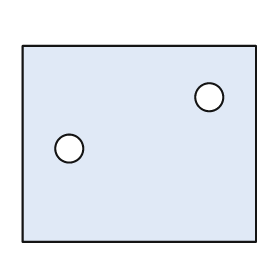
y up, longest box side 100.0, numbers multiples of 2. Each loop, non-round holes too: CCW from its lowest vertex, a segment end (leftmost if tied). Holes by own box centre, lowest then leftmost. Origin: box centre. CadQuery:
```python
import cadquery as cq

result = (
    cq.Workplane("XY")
    .moveTo(-50.0, -42.0)
    .lineTo(50.0, -42.0)
    .lineTo(50.0, 42.0)
    .lineTo(-50.0, 42.0)
    .close()
    .moveTo(-30.0, -2.0)
    .circle(6.0)
    .moveTo(30.0, 20.0)
    .circle(6.0)
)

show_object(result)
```